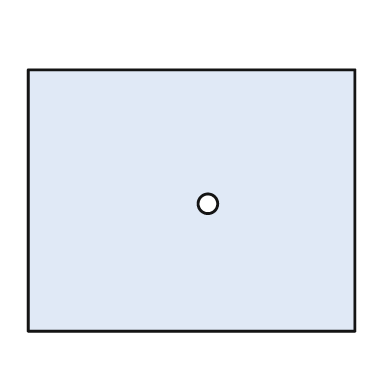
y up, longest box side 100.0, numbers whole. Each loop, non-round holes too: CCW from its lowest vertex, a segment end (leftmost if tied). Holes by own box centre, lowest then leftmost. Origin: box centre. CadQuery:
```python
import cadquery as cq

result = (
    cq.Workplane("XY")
    .moveTo(-50.0, -40.0)
    .lineTo(50.0, -40.0)
    .lineTo(50.0, 40.0)
    .lineTo(-50.0, 40.0)
    .close()
    .moveTo(5.0, -1.0)
    .circle(3.0)
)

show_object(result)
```